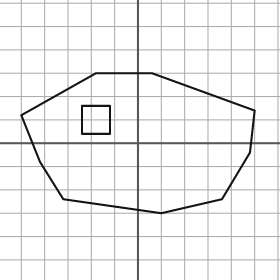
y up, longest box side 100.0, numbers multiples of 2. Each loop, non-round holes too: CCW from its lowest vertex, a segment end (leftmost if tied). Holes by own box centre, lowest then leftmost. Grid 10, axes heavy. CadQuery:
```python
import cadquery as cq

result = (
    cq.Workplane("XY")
    .moveTo(10.0, -30.0)
    .lineTo(36.0, -24.0)
    .lineTo(48.0, -4.0)
    .lineTo(50.0, 14.0)
    .lineTo(6.0, 30.0)
    .lineTo(-18.0, 30.0)
    .lineTo(-50.0, 12.0)
    .lineTo(-42.0, -8.0)
    .lineTo(-32.0, -24.0)
    .close()
    .moveTo(-24.0, 4.0)
    .lineTo(-12.0, 4.0)
    .lineTo(-12.0, 16.0)
    .lineTo(-24.0, 16.0)
    .close()
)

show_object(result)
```